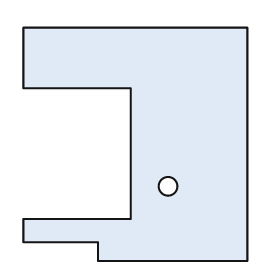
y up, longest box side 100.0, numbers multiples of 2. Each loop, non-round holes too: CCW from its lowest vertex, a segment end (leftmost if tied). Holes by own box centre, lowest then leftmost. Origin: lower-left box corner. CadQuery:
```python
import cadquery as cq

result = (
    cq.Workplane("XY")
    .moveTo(32.0, 0.0)
    .lineTo(96.0, 0.0)
    .lineTo(96.0, 100.0)
    .lineTo(0.0, 100.0)
    .lineTo(0.0, 74.0)
    .lineTo(46.0, 74.0)
    .lineTo(46.0, 18.0)
    .lineTo(0.0, 18.0)
    .lineTo(0.0, 8.0)
    .lineTo(32.0, 8.0)
    .close()
    .moveTo(62.0, 32.0)
    .circle(4.0)
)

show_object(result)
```